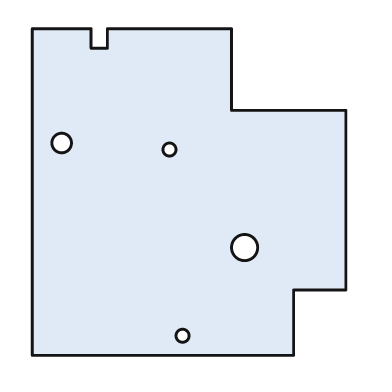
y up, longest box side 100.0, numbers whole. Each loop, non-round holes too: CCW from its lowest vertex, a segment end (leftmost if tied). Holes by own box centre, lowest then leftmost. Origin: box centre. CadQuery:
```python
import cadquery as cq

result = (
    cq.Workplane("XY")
    .moveTo(-48.0, -50.0)
    .lineTo(32.0, -50.0)
    .lineTo(32.0, -30.0)
    .lineTo(48.0, -30.0)
    .lineTo(48.0, 25.0)
    .lineTo(13.0, 25.0)
    .lineTo(13.0, 50.0)
    .lineTo(-25.0, 50.0)
    .lineTo(-25.0, 44.0)
    .lineTo(-30.0, 44.0)
    .lineTo(-30.0, 50.0)
    .lineTo(-48.0, 50.0)
    .close()
    .moveTo(-2.0, -44.0)
    .circle(2.0)
    .moveTo(17.0, -17.0)
    .circle(4.0)
    .moveTo(-6.0, 13.0)
    .circle(2.0)
    .moveTo(-39.0, 15.0)
    .circle(3.0)
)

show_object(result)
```